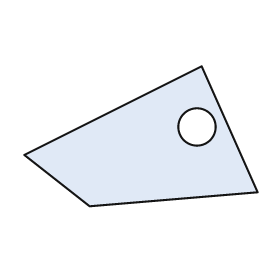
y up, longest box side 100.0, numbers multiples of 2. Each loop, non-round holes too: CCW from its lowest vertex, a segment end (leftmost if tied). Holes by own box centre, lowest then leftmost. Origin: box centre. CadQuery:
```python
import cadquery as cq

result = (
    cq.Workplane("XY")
    .moveTo(-22.0, -30.0)
    .lineTo(50.0, -24.0)
    .lineTo(26.0, 30.0)
    .lineTo(-50.0, -8.0)
    .close()
    .moveTo(24.0, 4.0)
    .circle(8.0)
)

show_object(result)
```